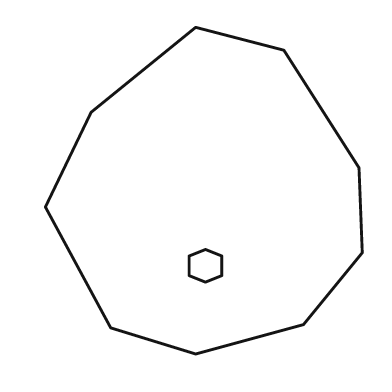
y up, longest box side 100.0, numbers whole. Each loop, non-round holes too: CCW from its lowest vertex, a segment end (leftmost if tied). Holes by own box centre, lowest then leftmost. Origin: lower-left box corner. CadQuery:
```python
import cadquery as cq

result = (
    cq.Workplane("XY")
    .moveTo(46.0, 0.0)
    .lineTo(79.0, 9.0)
    .lineTo(97.0, 31.0)
    .lineTo(96.0, 57.0)
    .lineTo(73.0, 93.0)
    .lineTo(46.0, 100.0)
    .lineTo(14.0, 74.0)
    .lineTo(0.0, 45.0)
    .lineTo(20.0, 8.0)
    .close()
    .moveTo(49.0, 22.0)
    .lineTo(54.0, 24.0)
    .lineTo(54.0, 30.0)
    .lineTo(49.0, 32.0)
    .lineTo(44.0, 30.0)
    .lineTo(44.0, 24.0)
    .close()
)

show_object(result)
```